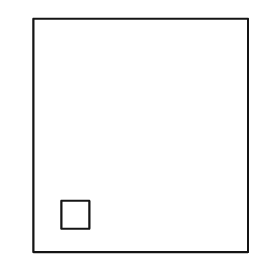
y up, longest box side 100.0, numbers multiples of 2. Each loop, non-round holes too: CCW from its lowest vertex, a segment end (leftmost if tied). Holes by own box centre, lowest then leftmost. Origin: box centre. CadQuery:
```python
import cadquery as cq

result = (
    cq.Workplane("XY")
    .moveTo(-46.0, -50.0)
    .lineTo(46.0, -50.0)
    .lineTo(46.0, 50.0)
    .lineTo(-46.0, 50.0)
    .close()
    .moveTo(-34.0, -40.0)
    .lineTo(-22.0, -40.0)
    .lineTo(-22.0, -28.0)
    .lineTo(-34.0, -28.0)
    .close()
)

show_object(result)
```